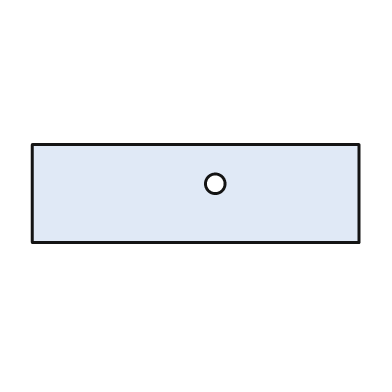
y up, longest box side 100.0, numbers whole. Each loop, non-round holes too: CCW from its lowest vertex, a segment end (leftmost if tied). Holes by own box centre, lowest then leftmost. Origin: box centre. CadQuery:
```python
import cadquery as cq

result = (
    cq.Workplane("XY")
    .moveTo(-50.0, -15.0)
    .lineTo(50.0, -15.0)
    .lineTo(50.0, 15.0)
    .lineTo(-50.0, 15.0)
    .close()
    .moveTo(6.0, 3.0)
    .circle(3.0)
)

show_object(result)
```